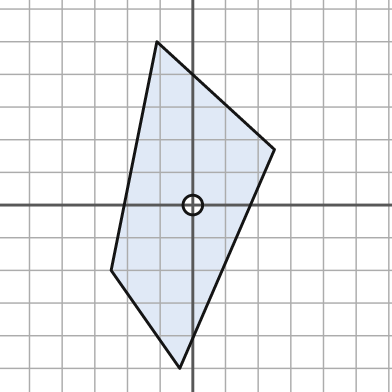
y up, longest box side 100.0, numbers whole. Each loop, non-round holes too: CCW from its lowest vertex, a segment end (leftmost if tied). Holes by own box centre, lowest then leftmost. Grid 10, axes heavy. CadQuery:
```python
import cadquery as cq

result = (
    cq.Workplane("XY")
    .moveTo(-4.0, -50.0)
    .lineTo(25.0, 17.0)
    .lineTo(-11.0, 50.0)
    .lineTo(-25.0, -20.0)
    .close()
    .moveTo(0.0, 0.0)
    .circle(3.0)
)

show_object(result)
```